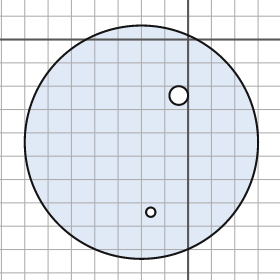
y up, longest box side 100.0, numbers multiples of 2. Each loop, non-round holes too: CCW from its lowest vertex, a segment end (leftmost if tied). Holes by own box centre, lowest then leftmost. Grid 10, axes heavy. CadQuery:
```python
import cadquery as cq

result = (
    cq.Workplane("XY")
    .moveTo(-20.0, -44.0)
    .circle(50.0)
    .moveTo(-16.0, -74.0)
    .circle(2.0)
    .moveTo(-4.0, -24.0)
    .circle(4.0)
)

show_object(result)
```